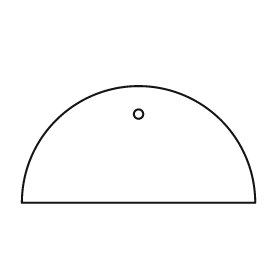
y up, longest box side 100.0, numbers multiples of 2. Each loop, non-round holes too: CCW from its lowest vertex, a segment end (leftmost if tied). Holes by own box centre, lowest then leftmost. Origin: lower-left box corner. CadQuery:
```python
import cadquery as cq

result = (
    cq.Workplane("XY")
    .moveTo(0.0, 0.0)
    .lineTo(100.0, 0.0)
    .threePointArc((50.0, 50.0), (0.0, 0.0))
    .close()
    .moveTo(50.0, 38.0)
    .circle(2.0)
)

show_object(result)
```